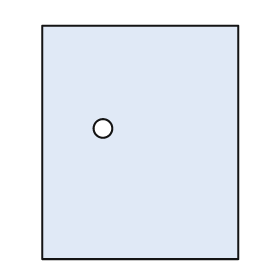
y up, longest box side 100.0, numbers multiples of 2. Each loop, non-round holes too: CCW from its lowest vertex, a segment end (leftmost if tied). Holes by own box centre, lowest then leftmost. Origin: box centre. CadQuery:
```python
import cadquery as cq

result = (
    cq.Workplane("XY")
    .moveTo(-42.0, -50.0)
    .lineTo(42.0, -50.0)
    .lineTo(42.0, 50.0)
    .lineTo(-42.0, 50.0)
    .close()
    .moveTo(-16.0, 6.0)
    .circle(4.0)
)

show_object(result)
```